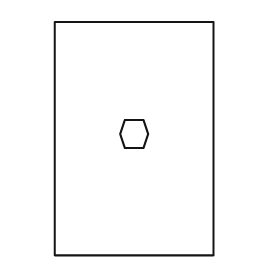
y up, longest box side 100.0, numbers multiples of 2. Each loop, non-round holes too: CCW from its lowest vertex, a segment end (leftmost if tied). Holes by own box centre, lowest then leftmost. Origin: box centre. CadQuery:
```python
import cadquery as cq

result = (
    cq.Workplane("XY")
    .moveTo(-34.0, -50.0)
    .lineTo(34.0, -50.0)
    .lineTo(34.0, 50.0)
    .lineTo(-34.0, 50.0)
    .close()
    .moveTo(-4.0, -4.0)
    .lineTo(4.0, -4.0)
    .lineTo(6.0, 2.0)
    .lineTo(4.0, 8.0)
    .lineTo(-4.0, 8.0)
    .lineTo(-6.0, 2.0)
    .close()
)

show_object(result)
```